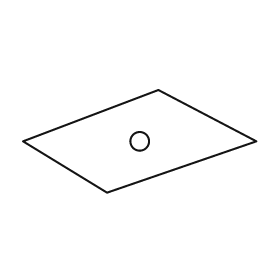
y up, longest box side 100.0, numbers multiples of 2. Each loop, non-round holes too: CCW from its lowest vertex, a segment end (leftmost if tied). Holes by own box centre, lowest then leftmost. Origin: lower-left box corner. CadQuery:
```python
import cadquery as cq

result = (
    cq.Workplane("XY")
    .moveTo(36.0, 0.0)
    .lineTo(100.0, 22.0)
    .lineTo(58.0, 44.0)
    .lineTo(0.0, 22.0)
    .close()
    .moveTo(50.0, 22.0)
    .circle(4.0)
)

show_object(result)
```